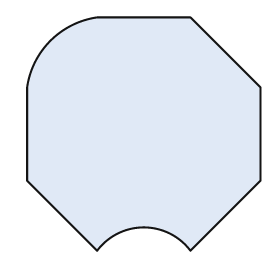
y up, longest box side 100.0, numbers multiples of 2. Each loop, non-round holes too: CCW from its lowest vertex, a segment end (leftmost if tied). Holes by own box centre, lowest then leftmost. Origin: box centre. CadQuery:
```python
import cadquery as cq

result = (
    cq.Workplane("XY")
    .moveTo(-20.0, -50.0)
    .threePointArc((0.0, -40.0), (20.0, -50.0))
    .lineTo(50.0, -20.0)
    .lineTo(50.0, 20.0)
    .lineTo(20.0, 50.0)
    .lineTo(-20.0, 50.0)
    .threePointArc((-40.0, 40.0), (-50.0, 20.0))
    .lineTo(-50.0, -20.0)
    .close()
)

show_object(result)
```